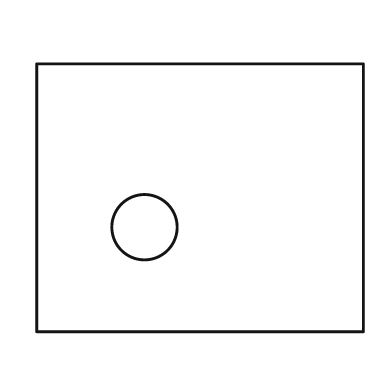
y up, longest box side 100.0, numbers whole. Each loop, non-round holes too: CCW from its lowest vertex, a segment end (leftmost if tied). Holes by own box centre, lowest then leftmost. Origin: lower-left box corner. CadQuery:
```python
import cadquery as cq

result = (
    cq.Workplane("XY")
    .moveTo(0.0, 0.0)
    .lineTo(100.0, 0.0)
    .lineTo(100.0, 82.0)
    .lineTo(0.0, 82.0)
    .close()
    .moveTo(33.0, 32.0)
    .circle(10.0)
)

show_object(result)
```